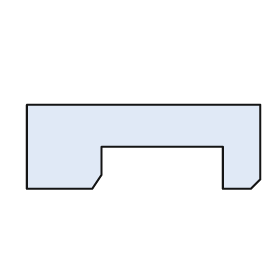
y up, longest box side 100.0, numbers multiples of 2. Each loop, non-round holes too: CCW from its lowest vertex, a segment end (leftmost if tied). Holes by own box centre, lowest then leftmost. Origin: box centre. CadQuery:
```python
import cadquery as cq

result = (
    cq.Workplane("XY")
    .moveTo(-50.0, -18.0)
    .lineTo(-22.0, -18.0)
    .lineTo(-18.0, -12.0)
    .lineTo(-18.0, 0.0)
    .lineTo(34.0, 0.0)
    .lineTo(34.0, -18.0)
    .lineTo(46.0, -18.0)
    .lineTo(50.0, -14.0)
    .lineTo(50.0, 18.0)
    .lineTo(-50.0, 18.0)
    .close()
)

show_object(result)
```